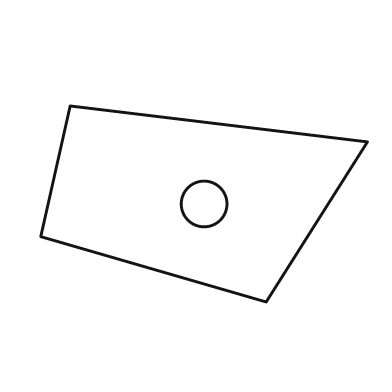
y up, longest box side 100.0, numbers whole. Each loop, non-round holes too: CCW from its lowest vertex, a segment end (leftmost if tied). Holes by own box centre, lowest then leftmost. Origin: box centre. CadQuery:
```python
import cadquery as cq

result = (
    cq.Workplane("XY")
    .moveTo(19.0, -30.0)
    .lineTo(50.0, 19.0)
    .lineTo(-41.0, 30.0)
    .lineTo(-50.0, -10.0)
    .close()
    .moveTo(0.0, 0.0)
    .circle(7.0)
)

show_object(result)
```